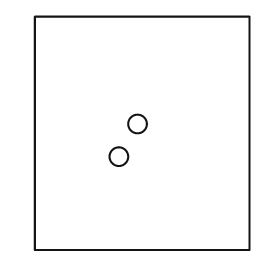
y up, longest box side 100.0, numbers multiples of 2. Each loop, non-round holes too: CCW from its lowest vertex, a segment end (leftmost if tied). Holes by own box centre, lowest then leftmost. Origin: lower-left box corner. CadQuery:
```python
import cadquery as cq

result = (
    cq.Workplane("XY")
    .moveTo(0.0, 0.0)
    .lineTo(92.0, 0.0)
    .lineTo(92.0, 100.0)
    .lineTo(0.0, 100.0)
    .close()
    .moveTo(36.0, 40.0)
    .circle(4.0)
    .moveTo(44.0, 54.0)
    .circle(4.0)
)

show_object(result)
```